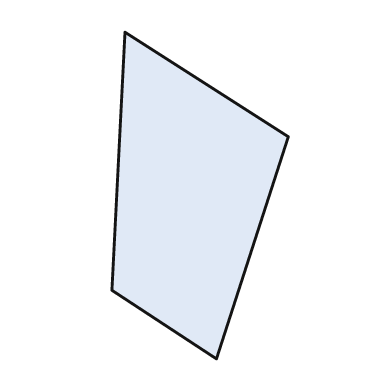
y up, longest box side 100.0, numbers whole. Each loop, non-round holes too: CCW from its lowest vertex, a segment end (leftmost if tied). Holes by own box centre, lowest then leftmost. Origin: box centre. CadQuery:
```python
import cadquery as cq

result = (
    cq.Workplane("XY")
    .moveTo(5.0, -50.0)
    .lineTo(27.0, 18.0)
    .lineTo(-23.0, 50.0)
    .lineTo(-27.0, -29.0)
    .close()
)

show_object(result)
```